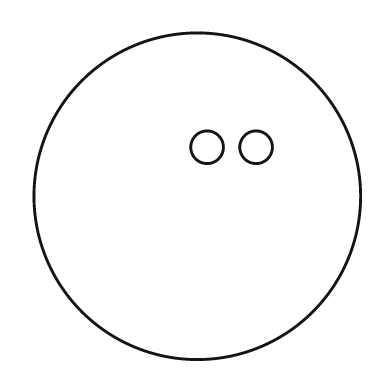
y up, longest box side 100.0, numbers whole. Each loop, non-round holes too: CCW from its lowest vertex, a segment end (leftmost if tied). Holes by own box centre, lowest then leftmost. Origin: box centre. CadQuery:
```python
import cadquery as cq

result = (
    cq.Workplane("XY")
    .moveTo(0.0, 0.0)
    .circle(50.0)
    .moveTo(3.0, 15.0)
    .circle(5.0)
    .moveTo(18.0, 15.0)
    .circle(5.0)
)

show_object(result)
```